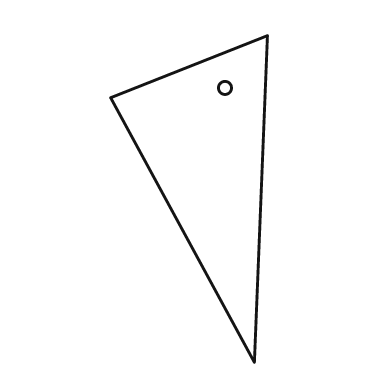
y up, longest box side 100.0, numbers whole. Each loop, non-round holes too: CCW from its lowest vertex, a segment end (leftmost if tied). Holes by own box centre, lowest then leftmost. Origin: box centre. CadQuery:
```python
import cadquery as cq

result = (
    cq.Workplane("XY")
    .moveTo(20.0, -50.0)
    .lineTo(24.0, 50.0)
    .lineTo(-24.0, 31.0)
    .close()
    .moveTo(11.0, 34.0)
    .circle(2.0)
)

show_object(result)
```